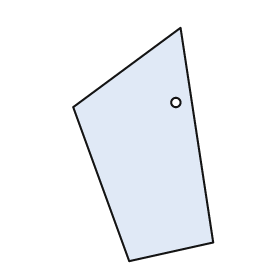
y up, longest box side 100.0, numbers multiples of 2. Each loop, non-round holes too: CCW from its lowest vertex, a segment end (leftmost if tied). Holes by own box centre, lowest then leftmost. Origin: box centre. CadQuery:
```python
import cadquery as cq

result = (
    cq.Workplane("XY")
    .moveTo(-6.0, -50.0)
    .lineTo(30.0, -42.0)
    .lineTo(16.0, 50.0)
    .lineTo(-30.0, 16.0)
    .close()
    .moveTo(14.0, 18.0)
    .circle(2.0)
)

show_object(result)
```